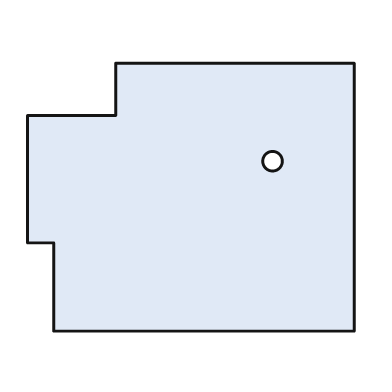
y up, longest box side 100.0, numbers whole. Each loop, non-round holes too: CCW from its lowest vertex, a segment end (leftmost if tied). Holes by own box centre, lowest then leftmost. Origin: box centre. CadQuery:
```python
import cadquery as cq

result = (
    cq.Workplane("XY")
    .moveTo(-42.0, -41.0)
    .lineTo(50.0, -41.0)
    .lineTo(50.0, 41.0)
    .lineTo(-23.0, 41.0)
    .lineTo(-23.0, 25.0)
    .lineTo(-50.0, 25.0)
    .lineTo(-50.0, -14.0)
    .lineTo(-42.0, -14.0)
    .close()
    .moveTo(25.0, 11.0)
    .circle(3.0)
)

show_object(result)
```